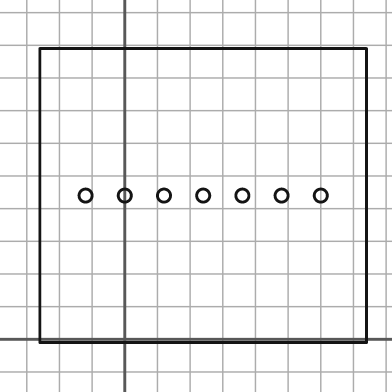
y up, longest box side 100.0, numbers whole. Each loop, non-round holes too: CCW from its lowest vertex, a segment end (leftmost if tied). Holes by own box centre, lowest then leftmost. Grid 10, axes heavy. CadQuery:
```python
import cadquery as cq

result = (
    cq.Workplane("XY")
    .moveTo(-26.0, -1.0)
    .lineTo(74.0, -1.0)
    .lineTo(74.0, 89.0)
    .lineTo(-26.0, 89.0)
    .close()
    .moveTo(-12.0, 44.0)
    .circle(2.0)
    .moveTo(0.0, 44.0)
    .circle(2.0)
    .moveTo(12.0, 44.0)
    .circle(2.0)
    .moveTo(24.0, 44.0)
    .circle(2.0)
    .moveTo(36.0, 44.0)
    .circle(2.0)
    .moveTo(48.0, 44.0)
    .circle(2.0)
    .moveTo(60.0, 44.0)
    .circle(2.0)
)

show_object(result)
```